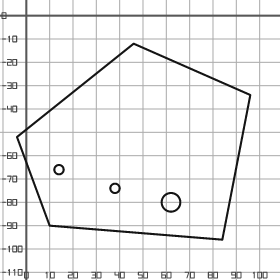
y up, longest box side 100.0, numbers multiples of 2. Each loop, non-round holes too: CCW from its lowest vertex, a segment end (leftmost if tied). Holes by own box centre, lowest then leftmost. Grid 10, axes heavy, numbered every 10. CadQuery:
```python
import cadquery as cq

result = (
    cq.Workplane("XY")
    .moveTo(84.0, -96.0)
    .lineTo(96.0, -34.0)
    .lineTo(46.0, -12.0)
    .lineTo(-4.0, -52.0)
    .lineTo(10.0, -90.0)
    .close()
    .moveTo(62.0, -80.0)
    .circle(4.0)
    .moveTo(38.0, -74.0)
    .circle(2.0)
    .moveTo(14.0, -66.0)
    .circle(2.0)
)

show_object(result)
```